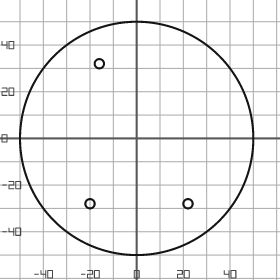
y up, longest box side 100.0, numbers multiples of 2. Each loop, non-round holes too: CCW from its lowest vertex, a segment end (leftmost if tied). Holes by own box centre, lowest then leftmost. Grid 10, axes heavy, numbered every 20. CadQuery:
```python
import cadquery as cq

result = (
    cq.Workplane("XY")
    .moveTo(0.0, 0.0)
    .circle(50.0)
    .moveTo(-20.0, -28.0)
    .circle(2.0)
    .moveTo(22.0, -28.0)
    .circle(2.0)
    .moveTo(-16.0, 32.0)
    .circle(2.0)
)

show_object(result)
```